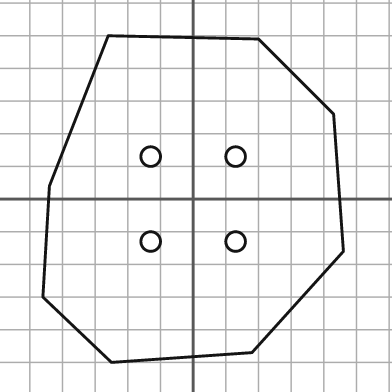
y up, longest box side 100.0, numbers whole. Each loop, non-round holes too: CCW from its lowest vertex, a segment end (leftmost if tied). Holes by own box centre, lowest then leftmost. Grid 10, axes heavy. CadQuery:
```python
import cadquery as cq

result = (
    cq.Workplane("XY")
    .moveTo(-25.0, -50.0)
    .lineTo(18.0, -47.0)
    .lineTo(46.0, -16.0)
    .lineTo(43.0, 26.0)
    .lineTo(20.0, 49.0)
    .lineTo(-26.0, 50.0)
    .lineTo(-44.0, 4.0)
    .lineTo(-46.0, -30.0)
    .close()
    .moveTo(-13.0, -13.0)
    .circle(3.0)
    .moveTo(13.0, -13.0)
    .circle(3.0)
    .moveTo(-13.0, 13.0)
    .circle(3.0)
    .moveTo(13.0, 13.0)
    .circle(3.0)
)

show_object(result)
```